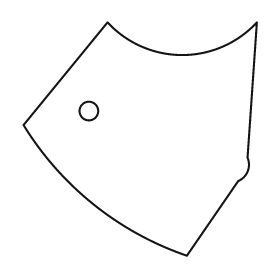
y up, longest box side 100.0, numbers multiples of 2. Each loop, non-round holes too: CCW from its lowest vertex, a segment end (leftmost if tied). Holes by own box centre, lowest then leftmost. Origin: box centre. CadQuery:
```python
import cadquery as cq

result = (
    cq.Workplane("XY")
    .moveTo(20.0, -50.0)
    .lineTo(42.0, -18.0)
    .threePointArc((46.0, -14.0), (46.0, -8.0))
    .lineTo(50.0, 50.0)
    .threePointArc((18.0, 36.0), (-14.0, 50.0))
    .lineTo(-50.0, 6.0)
    .threePointArc((-20.0, -28.0), (20.0, -50.0))
    .close()
    .moveTo(-22.0, 12.0)
    .circle(4.0)
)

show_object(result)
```